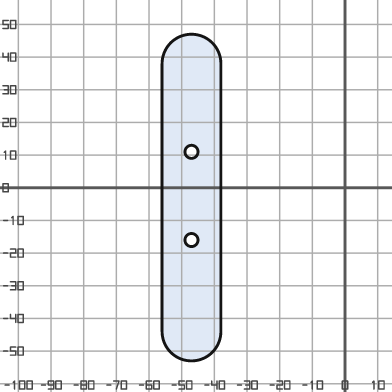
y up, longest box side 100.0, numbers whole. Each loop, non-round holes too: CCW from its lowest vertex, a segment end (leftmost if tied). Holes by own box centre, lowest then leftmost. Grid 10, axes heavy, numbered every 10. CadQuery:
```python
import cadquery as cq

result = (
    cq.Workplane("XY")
    .moveTo(-56.0, -44.0)
    .threePointArc((-47.0, -53.0), (-38.0, -44.0))
    .lineTo(-38.0, 38.0)
    .threePointArc((-47.0, 47.0), (-56.0, 38.0))
    .close()
    .moveTo(-47.0, -16.0)
    .circle(2.0)
    .moveTo(-47.0, 11.0)
    .circle(2.0)
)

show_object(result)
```